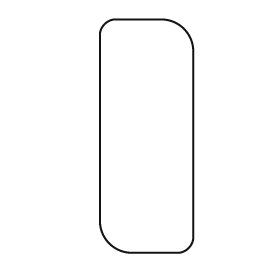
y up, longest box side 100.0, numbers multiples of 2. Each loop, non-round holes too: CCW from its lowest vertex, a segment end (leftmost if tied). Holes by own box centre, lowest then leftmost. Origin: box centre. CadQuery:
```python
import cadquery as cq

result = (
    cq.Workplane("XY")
    .moveTo(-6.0, -50.0)
    .lineTo(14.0, -50.0)
    .threePointArc((18.0, -48.0), (20.0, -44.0))
    .lineTo(20.0, 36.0)
    .threePointArc((16.0, 46.0), (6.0, 50.0))
    .lineTo(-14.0, 50.0)
    .threePointArc((-18.0, 48.0), (-20.0, 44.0))
    .lineTo(-20.0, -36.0)
    .threePointArc((-16.0, -46.0), (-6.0, -50.0))
    .close()
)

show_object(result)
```